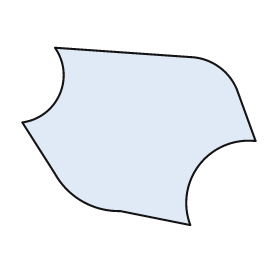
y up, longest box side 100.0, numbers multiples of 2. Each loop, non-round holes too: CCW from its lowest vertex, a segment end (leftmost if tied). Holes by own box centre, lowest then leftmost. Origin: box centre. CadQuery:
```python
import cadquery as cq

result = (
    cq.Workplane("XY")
    .moveTo(22.0, -38.0)
    .threePointArc((26.0, -12.0), (50.0, -2.0))
    .lineTo(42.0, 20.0)
    .threePointArc((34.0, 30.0), (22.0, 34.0))
    .lineTo(-36.0, 38.0)
    .threePointArc((-34.0, 18.0), (-50.0, 6.0))
    .lineTo(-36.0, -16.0)
    .threePointArc((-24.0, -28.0), (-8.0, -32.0))
    .close()
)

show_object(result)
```